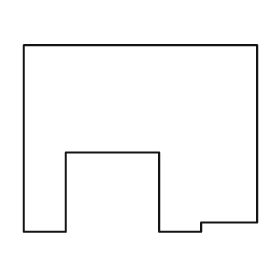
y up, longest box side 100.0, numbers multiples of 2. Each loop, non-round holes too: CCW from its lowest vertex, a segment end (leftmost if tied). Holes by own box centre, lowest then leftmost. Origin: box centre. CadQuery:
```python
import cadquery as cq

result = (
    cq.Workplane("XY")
    .moveTo(-50.0, -40.0)
    .lineTo(-32.0, -40.0)
    .lineTo(-32.0, -6.0)
    .lineTo(8.0, -6.0)
    .lineTo(8.0, -40.0)
    .lineTo(26.0, -40.0)
    .lineTo(26.0, -36.0)
    .lineTo(50.0, -36.0)
    .lineTo(50.0, 40.0)
    .lineTo(-50.0, 40.0)
    .close()
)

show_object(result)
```